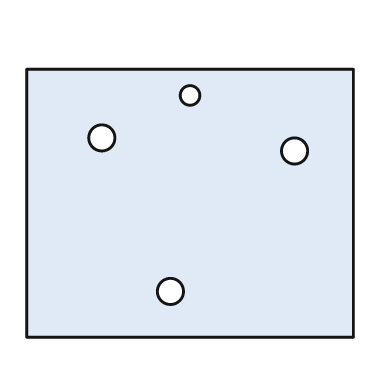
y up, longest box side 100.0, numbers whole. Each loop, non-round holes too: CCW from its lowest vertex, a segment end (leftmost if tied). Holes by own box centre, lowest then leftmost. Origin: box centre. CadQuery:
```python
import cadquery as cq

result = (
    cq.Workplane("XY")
    .moveTo(-50.0, -41.0)
    .lineTo(50.0, -41.0)
    .lineTo(50.0, 41.0)
    .lineTo(-50.0, 41.0)
    .close()
    .moveTo(-6.0, -27.0)
    .circle(4.0)
    .moveTo(32.0, 16.0)
    .circle(4.0)
    .moveTo(-27.0, 20.0)
    .circle(4.0)
    .moveTo(0.0, 33.0)
    .circle(3.0)
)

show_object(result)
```